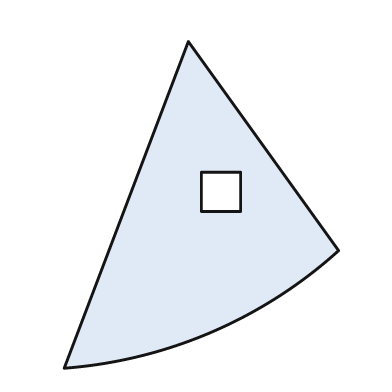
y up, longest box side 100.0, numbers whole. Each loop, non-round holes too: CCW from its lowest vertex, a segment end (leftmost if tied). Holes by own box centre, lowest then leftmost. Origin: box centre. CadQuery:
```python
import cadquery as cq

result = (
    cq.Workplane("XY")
    .moveTo(-42.0, -50.0)
    .threePointArc((3.0, -39.0), (42.0, -14.0))
    .lineTo(-4.0, 50.0)
    .close()
    .moveTo(0.0, -2.0)
    .lineTo(12.0, -2.0)
    .lineTo(12.0, 10.0)
    .lineTo(0.0, 10.0)
    .close()
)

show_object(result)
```